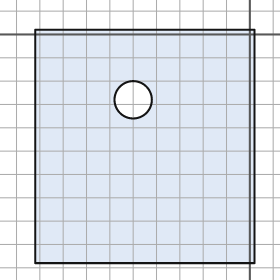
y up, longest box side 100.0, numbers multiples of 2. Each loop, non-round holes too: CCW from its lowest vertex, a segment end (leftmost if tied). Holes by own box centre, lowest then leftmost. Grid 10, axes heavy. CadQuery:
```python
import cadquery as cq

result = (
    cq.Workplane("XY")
    .moveTo(-92.0, -98.0)
    .lineTo(2.0, -98.0)
    .lineTo(2.0, 2.0)
    .lineTo(-92.0, 2.0)
    .close()
    .moveTo(-50.0, -28.0)
    .circle(8.0)
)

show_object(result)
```